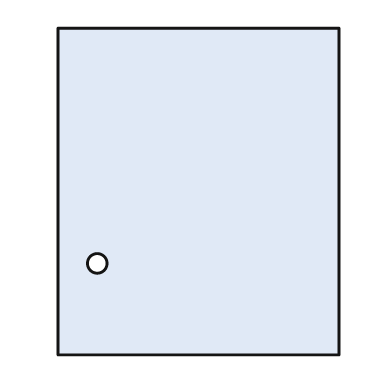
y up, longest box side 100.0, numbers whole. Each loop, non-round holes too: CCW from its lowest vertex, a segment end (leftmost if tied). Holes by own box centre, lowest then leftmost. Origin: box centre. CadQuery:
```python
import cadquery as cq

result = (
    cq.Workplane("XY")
    .moveTo(-43.0, -50.0)
    .lineTo(43.0, -50.0)
    .lineTo(43.0, 50.0)
    .lineTo(-43.0, 50.0)
    .close()
    .moveTo(-31.0, -22.0)
    .circle(3.0)
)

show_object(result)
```